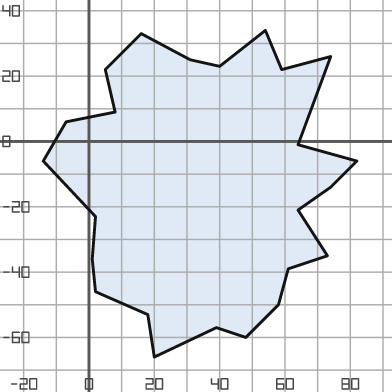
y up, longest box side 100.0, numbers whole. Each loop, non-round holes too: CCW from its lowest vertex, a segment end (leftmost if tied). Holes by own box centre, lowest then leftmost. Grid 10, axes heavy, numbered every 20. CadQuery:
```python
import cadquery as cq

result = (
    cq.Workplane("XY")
    .moveTo(20.0, -66.0)
    .lineTo(39.0, -57.0)
    .lineTo(48.0, -60.0)
    .lineTo(58.0, -50.0)
    .lineTo(61.0, -39.0)
    .lineTo(73.0, -35.0)
    .lineTo(64.0, -21.0)
    .lineTo(74.0, -14.0)
    .lineTo(82.0, -6.0)
    .lineTo(64.0, -1.0)
    .lineTo(74.0, 26.0)
    .lineTo(59.0, 22.0)
    .lineTo(54.0, 34.0)
    .lineTo(40.0, 23.0)
    .lineTo(31.0, 25.0)
    .lineTo(16.0, 33.0)
    .lineTo(5.0, 22.0)
    .lineTo(8.0, 9.0)
    .lineTo(-7.0, 6.0)
    .lineTo(-14.0, -6.0)
    .lineTo(2.0, -23.0)
    .lineTo(1.0, -36.0)
    .lineTo(2.0, -46.0)
    .lineTo(18.0, -53.0)
    .close()
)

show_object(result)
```